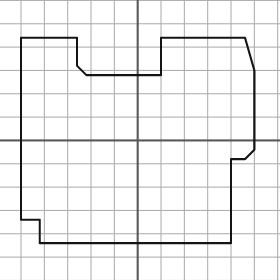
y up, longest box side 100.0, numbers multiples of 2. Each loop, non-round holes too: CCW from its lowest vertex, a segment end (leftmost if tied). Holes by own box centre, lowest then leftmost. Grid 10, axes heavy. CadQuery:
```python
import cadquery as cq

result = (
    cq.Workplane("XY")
    .moveTo(-42.0, -44.0)
    .lineTo(40.0, -44.0)
    .lineTo(40.0, -8.0)
    .lineTo(46.0, -8.0)
    .lineTo(50.0, -4.0)
    .lineTo(50.0, 30.0)
    .lineTo(46.0, 44.0)
    .lineTo(10.0, 44.0)
    .lineTo(10.0, 28.0)
    .lineTo(-22.0, 28.0)
    .lineTo(-26.0, 32.0)
    .lineTo(-26.0, 44.0)
    .lineTo(-50.0, 44.0)
    .lineTo(-50.0, -34.0)
    .lineTo(-42.0, -34.0)
    .close()
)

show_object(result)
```